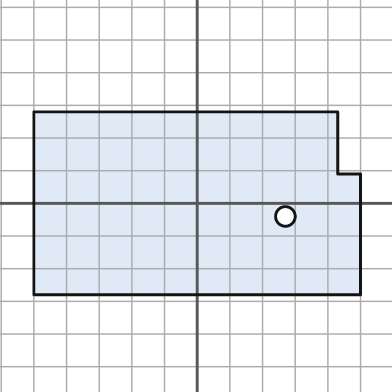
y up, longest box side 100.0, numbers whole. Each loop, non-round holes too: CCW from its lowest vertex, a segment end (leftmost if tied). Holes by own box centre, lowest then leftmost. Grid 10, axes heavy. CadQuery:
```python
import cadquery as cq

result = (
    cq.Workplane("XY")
    .moveTo(-50.0, -28.0)
    .lineTo(50.0, -28.0)
    .lineTo(50.0, 9.0)
    .lineTo(43.0, 9.0)
    .lineTo(43.0, 28.0)
    .lineTo(-50.0, 28.0)
    .close()
    .moveTo(27.0, -4.0)
    .circle(3.0)
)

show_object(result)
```